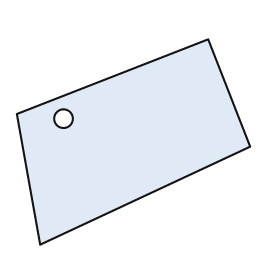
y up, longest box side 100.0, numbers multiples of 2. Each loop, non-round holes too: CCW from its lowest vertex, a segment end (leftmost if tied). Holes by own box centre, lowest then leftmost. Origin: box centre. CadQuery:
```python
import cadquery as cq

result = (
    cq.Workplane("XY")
    .moveTo(-40.0, -44.0)
    .lineTo(50.0, -2.0)
    .lineTo(32.0, 44.0)
    .lineTo(-50.0, 12.0)
    .close()
    .moveTo(-30.0, 10.0)
    .circle(4.0)
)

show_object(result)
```